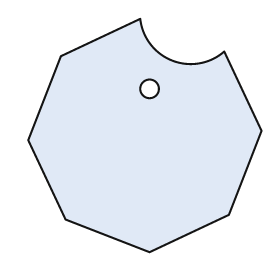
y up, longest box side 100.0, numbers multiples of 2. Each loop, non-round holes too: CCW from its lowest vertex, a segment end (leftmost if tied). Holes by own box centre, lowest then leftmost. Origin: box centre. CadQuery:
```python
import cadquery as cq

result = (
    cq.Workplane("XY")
    .moveTo(2.0, -50.0)
    .lineTo(36.0, -34.0)
    .lineTo(50.0, 2.0)
    .lineTo(34.0, 36.0)
    .threePointArc((12.0, 32.0), (-2.0, 50.0))
    .lineTo(-36.0, 34.0)
    .lineTo(-50.0, -2.0)
    .lineTo(-34.0, -36.0)
    .close()
    .moveTo(2.0, 20.0)
    .circle(4.0)
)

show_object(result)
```